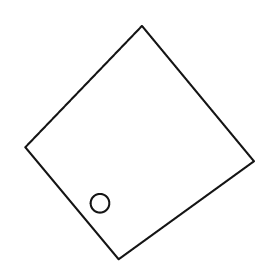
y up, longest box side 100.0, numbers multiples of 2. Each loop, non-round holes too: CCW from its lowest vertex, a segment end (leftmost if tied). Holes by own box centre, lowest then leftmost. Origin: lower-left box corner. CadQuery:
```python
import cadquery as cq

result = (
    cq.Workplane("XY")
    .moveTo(40.0, 0.0)
    .lineTo(98.0, 42.0)
    .lineTo(50.0, 100.0)
    .lineTo(0.0, 48.0)
    .close()
    .moveTo(32.0, 24.0)
    .circle(4.0)
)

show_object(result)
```